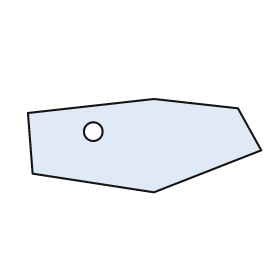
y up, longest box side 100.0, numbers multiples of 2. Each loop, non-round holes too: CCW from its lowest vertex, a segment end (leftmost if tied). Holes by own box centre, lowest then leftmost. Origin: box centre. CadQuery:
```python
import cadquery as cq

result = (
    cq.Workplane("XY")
    .moveTo(4.0, -20.0)
    .lineTo(50.0, -2.0)
    .lineTo(40.0, 16.0)
    .lineTo(4.0, 20.0)
    .lineTo(-50.0, 14.0)
    .lineTo(-48.0, -12.0)
    .close()
    .moveTo(-22.0, 6.0)
    .circle(4.0)
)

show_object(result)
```